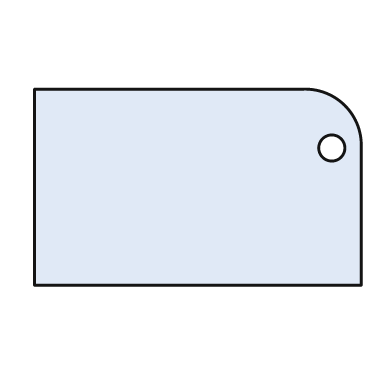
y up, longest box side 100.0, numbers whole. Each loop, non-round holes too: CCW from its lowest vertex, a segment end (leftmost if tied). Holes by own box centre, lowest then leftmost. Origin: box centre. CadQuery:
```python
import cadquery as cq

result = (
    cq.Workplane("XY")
    .moveTo(-50.0, -30.0)
    .lineTo(50.0, -30.0)
    .lineTo(50.0, 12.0)
    .threePointArc((45.0, 25.0), (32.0, 30.0))
    .lineTo(-50.0, 30.0)
    .close()
    .moveTo(41.0, 12.0)
    .circle(4.0)
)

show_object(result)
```